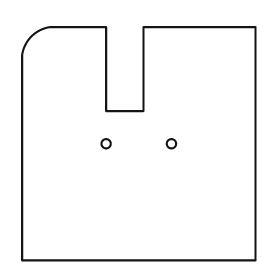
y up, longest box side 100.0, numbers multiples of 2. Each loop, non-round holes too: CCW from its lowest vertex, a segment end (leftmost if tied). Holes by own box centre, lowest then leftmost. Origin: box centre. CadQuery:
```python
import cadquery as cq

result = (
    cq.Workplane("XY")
    .moveTo(-50.0, -50.0)
    .lineTo(50.0, -50.0)
    .lineTo(50.0, 50.0)
    .lineTo(2.0, 50.0)
    .lineTo(2.0, 14.0)
    .lineTo(-14.0, 14.0)
    .lineTo(-14.0, 50.0)
    .lineTo(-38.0, 50.0)
    .threePointArc((-46.0, 46.0), (-50.0, 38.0))
    .close()
    .moveTo(-14.0, 0.0)
    .circle(2.0)
    .moveTo(14.0, 0.0)
    .circle(2.0)
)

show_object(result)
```